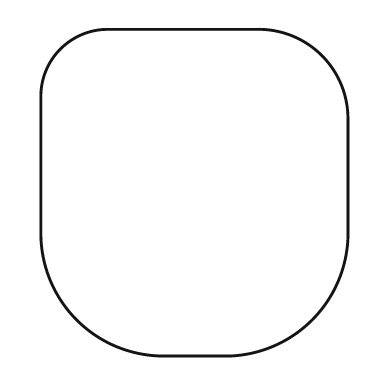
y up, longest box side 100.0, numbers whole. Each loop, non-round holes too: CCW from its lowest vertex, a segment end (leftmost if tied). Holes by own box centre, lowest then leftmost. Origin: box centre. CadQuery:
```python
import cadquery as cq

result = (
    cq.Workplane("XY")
    .moveTo(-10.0, -50.0)
    .lineTo(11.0, -50.0)
    .threePointArc((36.0, -39.0), (47.0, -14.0))
    .lineTo(47.0, 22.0)
    .threePointArc((39.0, 42.0), (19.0, 50.0))
    .lineTo(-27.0, 50.0)
    .threePointArc((-41.0, 44.0), (-47.0, 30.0))
    .lineTo(-47.0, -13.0)
    .threePointArc((-36.0, -39.0), (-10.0, -50.0))
    .close()
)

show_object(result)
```